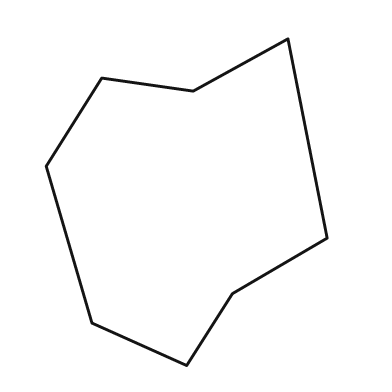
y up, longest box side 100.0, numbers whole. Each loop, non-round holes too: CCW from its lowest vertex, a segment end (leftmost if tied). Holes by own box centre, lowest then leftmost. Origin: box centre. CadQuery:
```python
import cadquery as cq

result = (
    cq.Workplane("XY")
    .moveTo(0.0, -50.0)
    .lineTo(14.0, -28.0)
    .lineTo(43.0, -11.0)
    .lineTo(31.0, 50.0)
    .lineTo(2.0, 34.0)
    .lineTo(-26.0, 38.0)
    .lineTo(-43.0, 11.0)
    .lineTo(-29.0, -37.0)
    .close()
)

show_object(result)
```